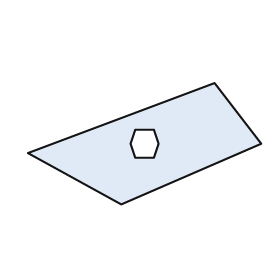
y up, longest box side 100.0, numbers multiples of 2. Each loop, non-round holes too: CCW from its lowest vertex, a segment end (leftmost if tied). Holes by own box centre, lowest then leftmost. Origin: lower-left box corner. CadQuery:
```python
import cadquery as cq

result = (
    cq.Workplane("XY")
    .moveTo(40.0, 0.0)
    .lineTo(100.0, 26.0)
    .lineTo(80.0, 52.0)
    .lineTo(0.0, 22.0)
    .close()
    .moveTo(46.0, 20.0)
    .lineTo(54.0, 20.0)
    .lineTo(56.0, 26.0)
    .lineTo(54.0, 32.0)
    .lineTo(46.0, 32.0)
    .lineTo(44.0, 26.0)
    .close()
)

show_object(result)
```